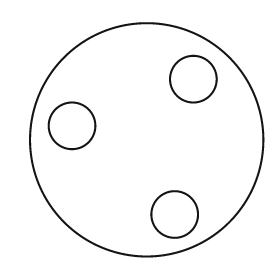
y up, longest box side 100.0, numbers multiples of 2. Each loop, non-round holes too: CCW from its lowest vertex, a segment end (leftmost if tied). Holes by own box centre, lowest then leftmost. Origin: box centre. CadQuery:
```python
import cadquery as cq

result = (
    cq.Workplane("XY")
    .moveTo(0.0, 0.0)
    .circle(50.0)
    .moveTo(12.0, -32.0)
    .circle(10.0)
    .moveTo(-32.0, 6.0)
    .circle(10.0)
    .moveTo(20.0, 26.0)
    .circle(10.0)
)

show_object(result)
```